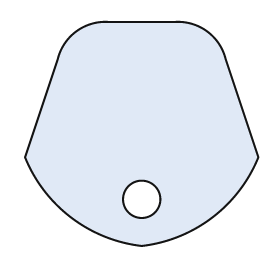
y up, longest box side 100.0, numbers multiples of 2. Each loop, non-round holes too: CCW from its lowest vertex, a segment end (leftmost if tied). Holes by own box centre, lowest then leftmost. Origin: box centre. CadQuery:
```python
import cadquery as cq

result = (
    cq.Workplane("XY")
    .moveTo(0.0, -48.0)
    .threePointArc((30.0, -36.0), (50.0, -10.0))
    .lineTo(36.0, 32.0)
    .threePointArc((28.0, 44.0), (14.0, 48.0))
    .lineTo(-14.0, 48.0)
    .threePointArc((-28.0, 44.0), (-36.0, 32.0))
    .lineTo(-50.0, -10.0)
    .threePointArc((-30.0, -36.0), (0.0, -48.0))
    .close()
    .moveTo(0.0, -28.0)
    .circle(8.0)
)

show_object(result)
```